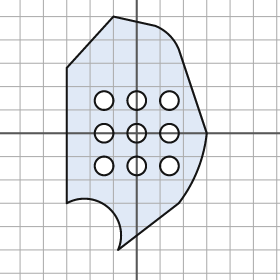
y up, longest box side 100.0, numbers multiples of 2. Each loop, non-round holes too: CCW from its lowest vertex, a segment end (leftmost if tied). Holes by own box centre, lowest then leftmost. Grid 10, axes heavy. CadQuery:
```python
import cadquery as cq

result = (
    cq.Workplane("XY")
    .moveTo(-8.0, -50.0)
    .lineTo(18.0, -30.0)
    .threePointArc((26.0, -16.0), (30.0, 0.0))
    .lineTo(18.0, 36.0)
    .threePointArc((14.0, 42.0), (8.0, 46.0))
    .lineTo(-10.0, 50.0)
    .lineTo(-30.0, 28.0)
    .lineTo(-30.0, -30.0)
    .threePointArc((-12.0, -32.0), (-8.0, -50.0))
    .close()
    .moveTo(-14.0, -14.0)
    .circle(4.0)
    .moveTo(0.0, -14.0)
    .circle(4.0)
    .moveTo(14.0, -14.0)
    .circle(4.0)
    .moveTo(-14.0, 0.0)
    .circle(4.0)
    .moveTo(0.0, 0.0)
    .circle(4.0)
    .moveTo(14.0, 0.0)
    .circle(4.0)
    .moveTo(-14.0, 14.0)
    .circle(4.0)
    .moveTo(0.0, 14.0)
    .circle(4.0)
    .moveTo(14.0, 14.0)
    .circle(4.0)
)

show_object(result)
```